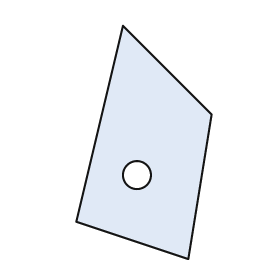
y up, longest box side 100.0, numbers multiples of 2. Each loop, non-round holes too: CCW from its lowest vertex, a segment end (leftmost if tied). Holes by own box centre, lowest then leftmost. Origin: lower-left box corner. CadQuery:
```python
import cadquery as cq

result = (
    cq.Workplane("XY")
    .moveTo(48.0, 0.0)
    .lineTo(58.0, 62.0)
    .lineTo(20.0, 100.0)
    .lineTo(0.0, 16.0)
    .close()
    .moveTo(26.0, 36.0)
    .circle(6.0)
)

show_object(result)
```